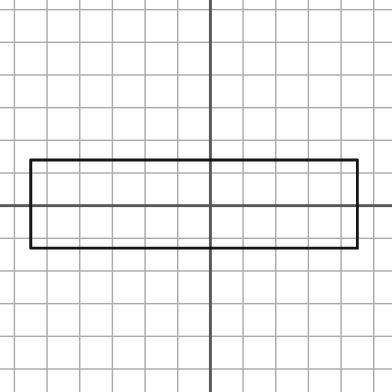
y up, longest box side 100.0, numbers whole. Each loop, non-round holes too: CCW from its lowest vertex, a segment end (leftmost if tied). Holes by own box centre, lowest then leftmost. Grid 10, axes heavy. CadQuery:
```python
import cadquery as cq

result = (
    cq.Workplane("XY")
    .moveTo(-55.0, -13.0)
    .lineTo(45.0, -13.0)
    .lineTo(45.0, 14.0)
    .lineTo(-55.0, 14.0)
    .close()
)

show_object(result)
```